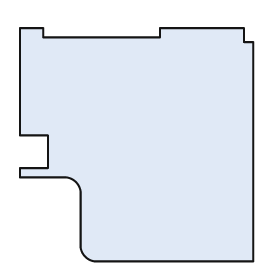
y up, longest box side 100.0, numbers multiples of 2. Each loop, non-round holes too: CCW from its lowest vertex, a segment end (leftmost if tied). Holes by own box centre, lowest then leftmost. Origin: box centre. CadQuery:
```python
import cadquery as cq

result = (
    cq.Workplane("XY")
    .moveTo(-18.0, -50.0)
    .lineTo(50.0, -50.0)
    .lineTo(50.0, 44.0)
    .lineTo(46.0, 44.0)
    .lineTo(46.0, 50.0)
    .lineTo(10.0, 50.0)
    .lineTo(10.0, 46.0)
    .lineTo(-40.0, 46.0)
    .lineTo(-40.0, 50.0)
    .lineTo(-50.0, 50.0)
    .lineTo(-50.0, 4.0)
    .lineTo(-38.0, 4.0)
    .lineTo(-38.0, -10.0)
    .lineTo(-50.0, -10.0)
    .lineTo(-50.0, -14.0)
    .lineTo(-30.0, -14.0)
    .threePointArc((-26.0, -16.0), (-24.0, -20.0))
    .lineTo(-24.0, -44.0)
    .threePointArc((-22.0, -48.0), (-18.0, -50.0))
    .close()
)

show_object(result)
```